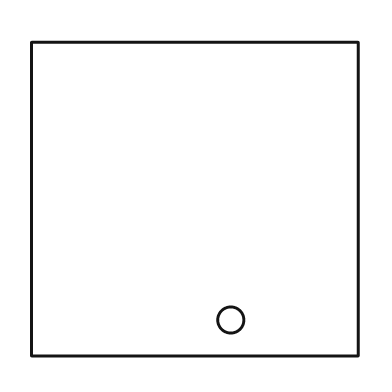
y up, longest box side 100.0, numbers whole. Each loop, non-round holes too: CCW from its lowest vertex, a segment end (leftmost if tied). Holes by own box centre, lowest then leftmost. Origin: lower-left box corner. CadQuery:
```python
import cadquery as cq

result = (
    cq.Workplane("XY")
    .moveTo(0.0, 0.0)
    .lineTo(100.0, 0.0)
    .lineTo(100.0, 96.0)
    .lineTo(0.0, 96.0)
    .close()
    .moveTo(61.0, 11.0)
    .circle(4.0)
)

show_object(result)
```